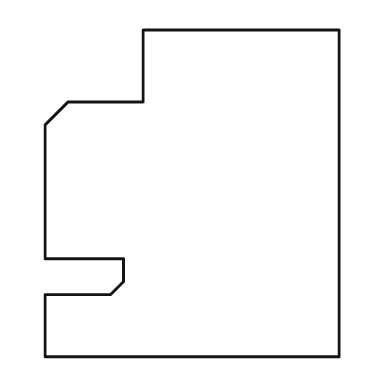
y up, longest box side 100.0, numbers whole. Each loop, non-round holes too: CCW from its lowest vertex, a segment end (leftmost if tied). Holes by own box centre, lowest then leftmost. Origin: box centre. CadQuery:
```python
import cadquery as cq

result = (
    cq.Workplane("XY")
    .moveTo(-45.0, -50.0)
    .lineTo(45.0, -50.0)
    .lineTo(45.0, 50.0)
    .lineTo(-15.0, 50.0)
    .lineTo(-15.0, 28.0)
    .lineTo(-38.0, 28.0)
    .lineTo(-45.0, 21.0)
    .lineTo(-45.0, -20.0)
    .lineTo(-21.0, -20.0)
    .lineTo(-21.0, -27.0)
    .lineTo(-25.0, -31.0)
    .lineTo(-45.0, -31.0)
    .close()
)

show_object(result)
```